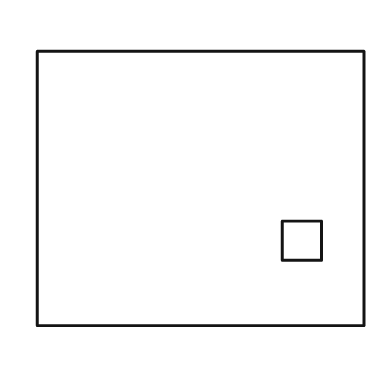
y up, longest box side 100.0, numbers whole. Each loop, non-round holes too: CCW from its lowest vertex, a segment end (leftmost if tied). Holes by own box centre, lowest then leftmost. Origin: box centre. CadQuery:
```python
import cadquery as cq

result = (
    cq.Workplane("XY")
    .moveTo(-50.0, -42.0)
    .lineTo(50.0, -42.0)
    .lineTo(50.0, 42.0)
    .lineTo(-50.0, 42.0)
    .close()
    .moveTo(25.0, -22.0)
    .lineTo(37.0, -22.0)
    .lineTo(37.0, -10.0)
    .lineTo(25.0, -10.0)
    .close()
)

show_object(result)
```